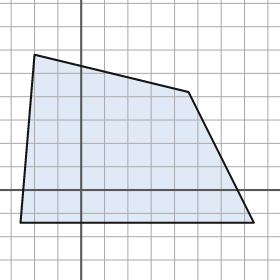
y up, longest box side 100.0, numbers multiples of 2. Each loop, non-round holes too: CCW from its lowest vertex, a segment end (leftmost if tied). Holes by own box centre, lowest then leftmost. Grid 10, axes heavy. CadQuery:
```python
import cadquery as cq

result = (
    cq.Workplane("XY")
    .moveTo(-26.0, -14.0)
    .lineTo(74.0, -14.0)
    .lineTo(46.0, 42.0)
    .lineTo(-20.0, 58.0)
    .close()
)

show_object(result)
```